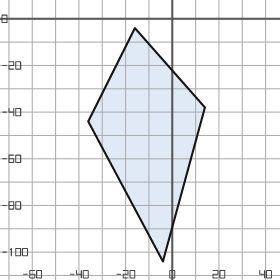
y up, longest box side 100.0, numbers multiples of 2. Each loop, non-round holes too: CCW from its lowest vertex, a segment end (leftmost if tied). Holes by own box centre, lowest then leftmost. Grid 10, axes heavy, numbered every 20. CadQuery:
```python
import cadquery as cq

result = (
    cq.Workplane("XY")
    .moveTo(-4.0, -104.0)
    .lineTo(14.0, -38.0)
    .lineTo(-16.0, -4.0)
    .lineTo(-36.0, -44.0)
    .close()
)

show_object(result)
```